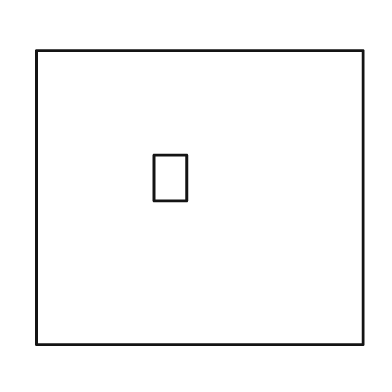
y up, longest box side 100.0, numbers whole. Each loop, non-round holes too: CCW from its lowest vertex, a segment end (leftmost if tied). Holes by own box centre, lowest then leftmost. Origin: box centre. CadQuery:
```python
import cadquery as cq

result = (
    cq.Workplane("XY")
    .moveTo(-50.0, -45.0)
    .lineTo(50.0, -45.0)
    .lineTo(50.0, 45.0)
    .lineTo(-50.0, 45.0)
    .close()
    .moveTo(-14.0, -1.0)
    .lineTo(-4.0, -1.0)
    .lineTo(-4.0, 13.0)
    .lineTo(-14.0, 13.0)
    .close()
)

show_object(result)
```